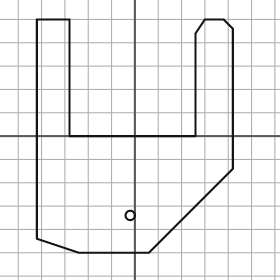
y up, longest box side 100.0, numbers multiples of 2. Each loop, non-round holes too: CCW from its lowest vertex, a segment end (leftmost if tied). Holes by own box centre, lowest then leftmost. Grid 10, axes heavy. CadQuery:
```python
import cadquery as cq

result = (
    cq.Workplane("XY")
    .moveTo(-24.0, -50.0)
    .lineTo(6.0, -50.0)
    .lineTo(42.0, -14.0)
    .lineTo(42.0, 46.0)
    .lineTo(38.0, 50.0)
    .lineTo(30.0, 50.0)
    .lineTo(26.0, 44.0)
    .lineTo(26.0, 0.0)
    .lineTo(-28.0, 0.0)
    .lineTo(-28.0, 50.0)
    .lineTo(-42.0, 50.0)
    .lineTo(-42.0, -44.0)
    .close()
    .moveTo(-2.0, -34.0)
    .circle(2.0)
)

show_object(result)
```